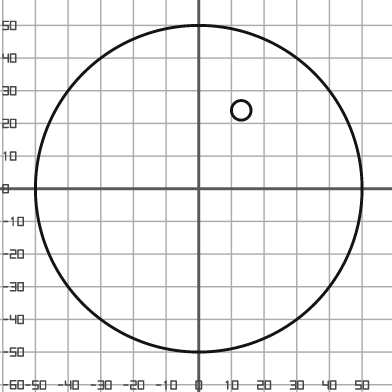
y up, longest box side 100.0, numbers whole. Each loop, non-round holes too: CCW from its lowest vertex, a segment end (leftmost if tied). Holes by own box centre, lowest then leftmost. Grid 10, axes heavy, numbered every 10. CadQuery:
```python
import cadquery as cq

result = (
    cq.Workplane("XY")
    .moveTo(0.0, 0.0)
    .circle(50.0)
    .moveTo(13.0, 24.0)
    .circle(3.0)
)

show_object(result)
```